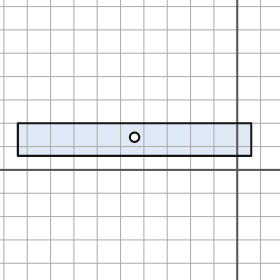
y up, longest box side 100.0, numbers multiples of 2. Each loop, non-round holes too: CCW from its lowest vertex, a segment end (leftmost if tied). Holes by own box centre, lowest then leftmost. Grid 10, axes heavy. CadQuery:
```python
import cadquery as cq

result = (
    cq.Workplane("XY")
    .moveTo(-94.0, 6.0)
    .lineTo(6.0, 6.0)
    .lineTo(6.0, 20.0)
    .lineTo(-94.0, 20.0)
    .close()
    .moveTo(-44.0, 14.0)
    .circle(2.0)
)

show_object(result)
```